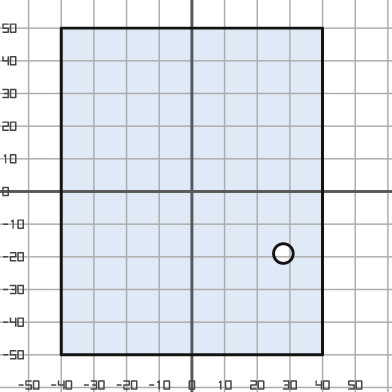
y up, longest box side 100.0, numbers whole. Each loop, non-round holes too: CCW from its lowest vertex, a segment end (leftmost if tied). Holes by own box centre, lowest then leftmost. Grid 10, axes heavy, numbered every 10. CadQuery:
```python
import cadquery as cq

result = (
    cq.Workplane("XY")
    .moveTo(-40.0, -50.0)
    .lineTo(40.0, -50.0)
    .lineTo(40.0, 50.0)
    .lineTo(-40.0, 50.0)
    .close()
    .moveTo(28.0, -19.0)
    .circle(3.0)
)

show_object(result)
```